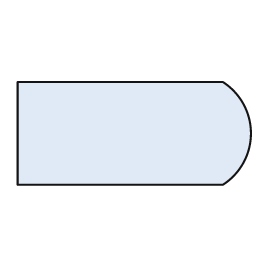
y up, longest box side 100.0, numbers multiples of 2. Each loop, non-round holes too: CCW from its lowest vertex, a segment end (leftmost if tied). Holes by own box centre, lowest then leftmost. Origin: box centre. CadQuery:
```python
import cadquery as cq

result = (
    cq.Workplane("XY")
    .moveTo(-50.0, -22.0)
    .lineTo(38.0, -22.0)
    .threePointArc((50.0, 0.0), (38.0, 22.0))
    .lineTo(-50.0, 22.0)
    .close()
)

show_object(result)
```